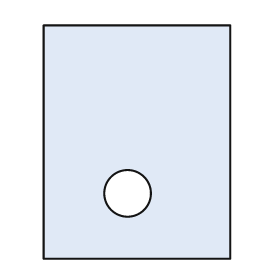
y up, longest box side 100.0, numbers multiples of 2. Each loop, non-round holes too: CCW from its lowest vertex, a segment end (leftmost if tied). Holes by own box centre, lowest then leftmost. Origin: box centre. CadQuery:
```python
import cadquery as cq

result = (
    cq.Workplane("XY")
    .moveTo(-40.0, -50.0)
    .lineTo(40.0, -50.0)
    .lineTo(40.0, 50.0)
    .lineTo(-40.0, 50.0)
    .close()
    .moveTo(-4.0, -22.0)
    .circle(10.0)
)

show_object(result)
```